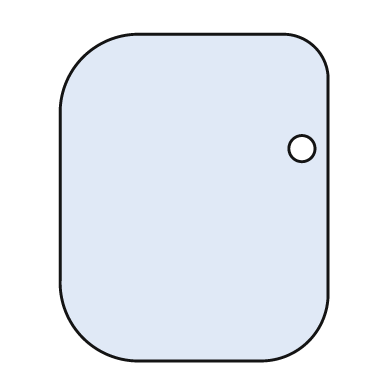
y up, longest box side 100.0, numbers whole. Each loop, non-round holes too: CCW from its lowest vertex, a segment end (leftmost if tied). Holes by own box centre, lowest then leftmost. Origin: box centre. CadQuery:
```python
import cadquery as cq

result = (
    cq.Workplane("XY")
    .moveTo(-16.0, -50.0)
    .lineTo(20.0, -50.0)
    .threePointArc((35.0, -44.0), (41.0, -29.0))
    .lineTo(41.0, 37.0)
    .threePointArc((37.0, 46.0), (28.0, 50.0))
    .lineTo(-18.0, 50.0)
    .threePointArc((-34.0, 43.0), (-41.0, 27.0))
    .lineTo(-41.0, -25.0)
    .threePointArc((-34.0, -43.0), (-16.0, -50.0))
    .close()
    .moveTo(33.0, 15.0)
    .circle(4.0)
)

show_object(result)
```